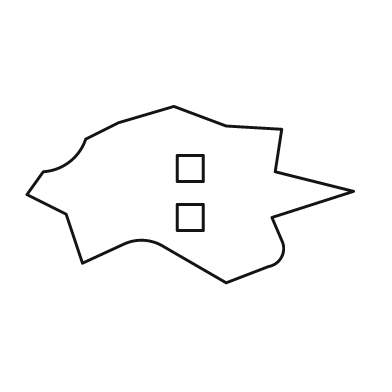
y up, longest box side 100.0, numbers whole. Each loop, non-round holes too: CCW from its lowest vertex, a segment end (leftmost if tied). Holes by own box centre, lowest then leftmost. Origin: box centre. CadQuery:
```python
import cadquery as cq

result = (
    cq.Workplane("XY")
    .moveTo(11.0, -27.0)
    .lineTo(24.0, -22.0)
    .threePointArc((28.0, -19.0), (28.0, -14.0))
    .lineTo(25.0, -7.0)
    .lineTo(50.0, 1.0)
    .lineTo(26.0, 7.0)
    .lineTo(28.0, 20.0)
    .lineTo(11.0, 21.0)
    .lineTo(-5.0, 27.0)
    .lineTo(-22.0, 22.0)
    .lineTo(-32.0, 17.0)
    .threePointArc((-37.0, 10.0), (-45.0, 7.0))
    .lineTo(-50.0, 0.0)
    .lineTo(-38.0, -6.0)
    .lineTo(-33.0, -21.0)
    .lineTo(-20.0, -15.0)
    .threePointArc((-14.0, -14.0), (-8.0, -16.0))
    .close()
    .moveTo(-4.0, -11.0)
    .lineTo(4.0, -11.0)
    .lineTo(4.0, -3.0)
    .lineTo(-4.0, -3.0)
    .close()
    .moveTo(-4.0, 4.0)
    .lineTo(4.0, 4.0)
    .lineTo(4.0, 12.0)
    .lineTo(-4.0, 12.0)
    .close()
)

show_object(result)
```